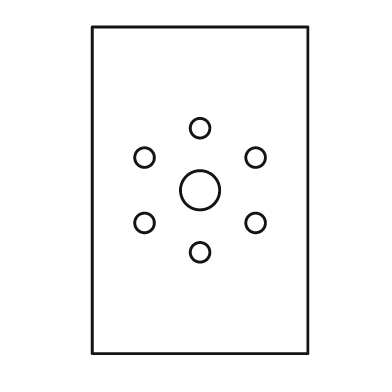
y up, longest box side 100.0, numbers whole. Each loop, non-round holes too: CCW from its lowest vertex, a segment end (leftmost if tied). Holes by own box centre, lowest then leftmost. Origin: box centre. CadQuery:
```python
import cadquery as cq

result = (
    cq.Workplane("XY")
    .moveTo(-33.0, -50.0)
    .lineTo(33.0, -50.0)
    .lineTo(33.0, 50.0)
    .lineTo(-33.0, 50.0)
    .close()
    .moveTo(0.0, -19.0)
    .circle(3.0)
    .moveTo(-17.0, -10.0)
    .circle(3.0)
    .moveTo(17.0, -10.0)
    .circle(3.0)
    .moveTo(0.0, 0.0)
    .circle(6.0)
    .moveTo(-17.0, 10.0)
    .circle(3.0)
    .moveTo(17.0, 10.0)
    .circle(3.0)
    .moveTo(0.0, 19.0)
    .circle(3.0)
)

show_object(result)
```